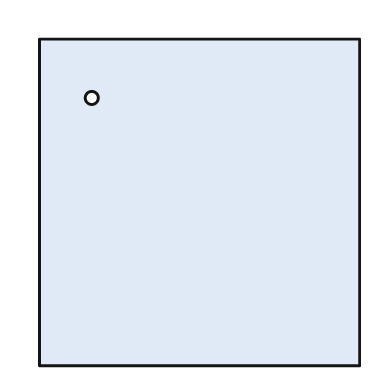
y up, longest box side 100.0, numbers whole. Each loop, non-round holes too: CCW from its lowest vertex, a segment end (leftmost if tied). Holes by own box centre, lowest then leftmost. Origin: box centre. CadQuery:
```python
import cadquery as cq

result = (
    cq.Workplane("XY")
    .moveTo(-49.0, -50.0)
    .lineTo(49.0, -50.0)
    .lineTo(49.0, 50.0)
    .lineTo(-49.0, 50.0)
    .close()
    .moveTo(-33.0, 32.0)
    .circle(2.0)
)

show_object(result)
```